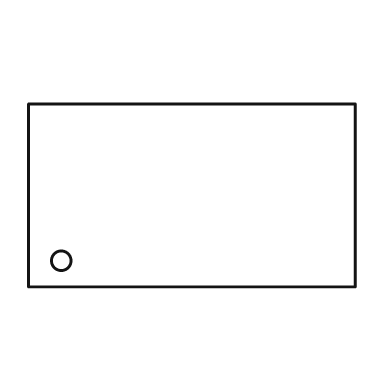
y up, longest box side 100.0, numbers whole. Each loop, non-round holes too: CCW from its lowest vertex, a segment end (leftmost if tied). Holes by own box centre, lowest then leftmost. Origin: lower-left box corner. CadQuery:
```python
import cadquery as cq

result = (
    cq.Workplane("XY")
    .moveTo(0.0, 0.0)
    .lineTo(100.0, 0.0)
    .lineTo(100.0, 56.0)
    .lineTo(0.0, 56.0)
    .close()
    .moveTo(10.0, 8.0)
    .circle(3.0)
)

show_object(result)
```